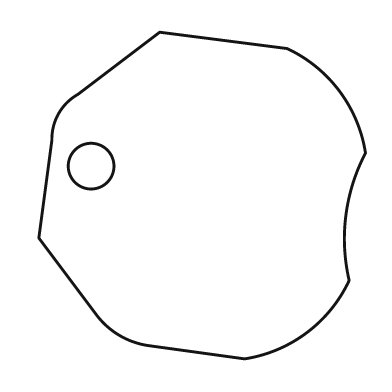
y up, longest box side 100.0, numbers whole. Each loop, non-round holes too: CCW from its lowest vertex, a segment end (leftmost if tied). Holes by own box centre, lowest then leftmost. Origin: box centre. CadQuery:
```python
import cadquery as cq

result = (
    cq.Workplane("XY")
    .moveTo(13.0, -50.0)
    .threePointArc((32.0, -42.0), (45.0, -26.0))
    .threePointArc((44.0, -6.0), (50.0, 13.0))
    .threePointArc((42.0, 32.0), (26.0, 45.0))
    .lineTo(-13.0, 50.0)
    .lineTo(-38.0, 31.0)
    .threePointArc((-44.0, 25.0), (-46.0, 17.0))
    .lineTo(-50.0, -13.0)
    .lineTo(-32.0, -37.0)
    .threePointArc((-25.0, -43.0), (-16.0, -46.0))
    .close()
    .moveTo(-34.0, 9.0)
    .circle(7.0)
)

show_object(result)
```